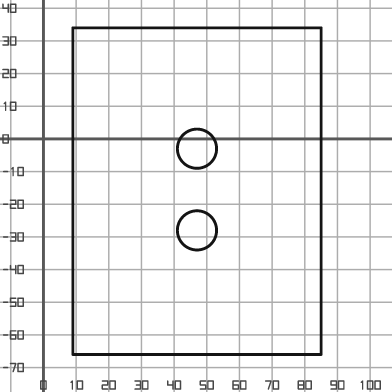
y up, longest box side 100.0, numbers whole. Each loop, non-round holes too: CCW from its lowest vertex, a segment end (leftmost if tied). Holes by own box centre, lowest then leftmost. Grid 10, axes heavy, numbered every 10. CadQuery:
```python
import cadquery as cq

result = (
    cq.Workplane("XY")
    .moveTo(9.0, -66.0)
    .lineTo(85.0, -66.0)
    .lineTo(85.0, 34.0)
    .lineTo(9.0, 34.0)
    .close()
    .moveTo(47.0, -28.0)
    .circle(6.0)
    .moveTo(47.0, -3.0)
    .circle(6.0)
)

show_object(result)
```